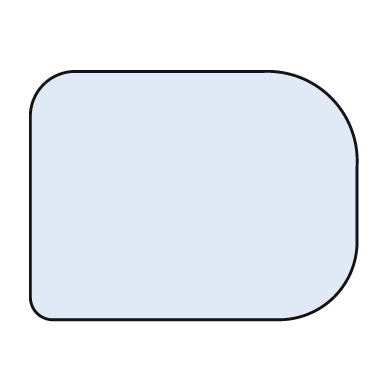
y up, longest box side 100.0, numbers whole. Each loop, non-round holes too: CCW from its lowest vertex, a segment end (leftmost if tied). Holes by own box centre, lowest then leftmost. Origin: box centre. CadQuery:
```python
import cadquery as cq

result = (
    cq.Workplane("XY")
    .moveTo(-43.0, -38.0)
    .lineTo(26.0, -38.0)
    .threePointArc((43.0, -31.0), (50.0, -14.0))
    .lineTo(50.0, 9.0)
    .threePointArc((42.0, 30.0), (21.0, 38.0))
    .lineTo(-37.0, 38.0)
    .threePointArc((-46.0, 34.0), (-50.0, 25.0))
    .lineTo(-50.0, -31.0)
    .threePointArc((-48.0, -36.0), (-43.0, -38.0))
    .close()
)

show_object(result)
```